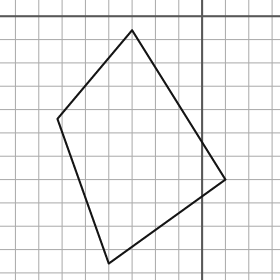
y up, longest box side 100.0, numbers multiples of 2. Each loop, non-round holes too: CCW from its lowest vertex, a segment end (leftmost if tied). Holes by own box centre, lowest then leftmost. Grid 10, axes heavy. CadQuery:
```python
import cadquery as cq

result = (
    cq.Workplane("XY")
    .moveTo(-40.0, -106.0)
    .lineTo(10.0, -70.0)
    .lineTo(-30.0, -6.0)
    .lineTo(-62.0, -44.0)
    .close()
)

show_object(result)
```